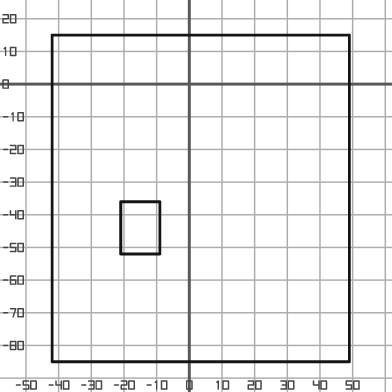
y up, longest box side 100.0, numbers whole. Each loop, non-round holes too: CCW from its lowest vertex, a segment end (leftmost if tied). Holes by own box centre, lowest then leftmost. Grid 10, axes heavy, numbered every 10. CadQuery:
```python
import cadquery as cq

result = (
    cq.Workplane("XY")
    .moveTo(-42.0, -85.0)
    .lineTo(49.0, -85.0)
    .lineTo(49.0, 15.0)
    .lineTo(-42.0, 15.0)
    .close()
    .moveTo(-21.0, -52.0)
    .lineTo(-9.0, -52.0)
    .lineTo(-9.0, -36.0)
    .lineTo(-21.0, -36.0)
    .close()
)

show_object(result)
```